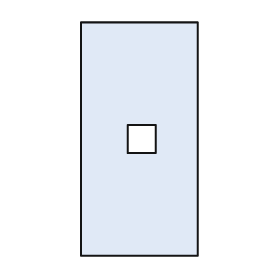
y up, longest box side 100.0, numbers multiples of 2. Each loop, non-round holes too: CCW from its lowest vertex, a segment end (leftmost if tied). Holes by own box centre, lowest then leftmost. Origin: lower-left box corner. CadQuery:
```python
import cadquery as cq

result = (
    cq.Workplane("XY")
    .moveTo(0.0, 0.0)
    .lineTo(50.0, 0.0)
    .lineTo(50.0, 100.0)
    .lineTo(0.0, 100.0)
    .close()
    .moveTo(20.0, 44.0)
    .lineTo(32.0, 44.0)
    .lineTo(32.0, 56.0)
    .lineTo(20.0, 56.0)
    .close()
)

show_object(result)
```